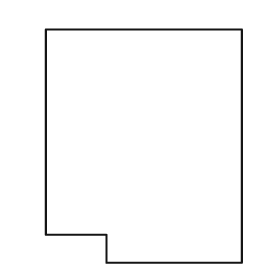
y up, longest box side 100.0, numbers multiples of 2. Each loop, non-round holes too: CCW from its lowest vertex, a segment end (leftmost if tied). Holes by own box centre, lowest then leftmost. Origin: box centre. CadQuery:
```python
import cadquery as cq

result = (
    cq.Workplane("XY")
    .moveTo(-16.0, -50.0)
    .lineTo(42.0, -50.0)
    .lineTo(42.0, 50.0)
    .lineTo(-42.0, 50.0)
    .lineTo(-42.0, -38.0)
    .lineTo(-16.0, -38.0)
    .close()
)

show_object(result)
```